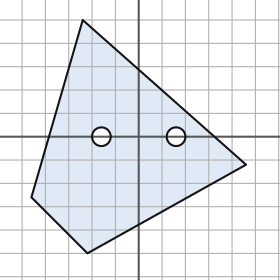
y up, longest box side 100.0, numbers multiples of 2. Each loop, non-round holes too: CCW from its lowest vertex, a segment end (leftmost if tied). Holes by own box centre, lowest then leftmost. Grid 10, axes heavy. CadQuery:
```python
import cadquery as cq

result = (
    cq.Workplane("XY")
    .moveTo(-22.0, -50.0)
    .lineTo(46.0, -12.0)
    .lineTo(-24.0, 50.0)
    .lineTo(-46.0, -26.0)
    .close()
    .moveTo(-16.0, 0.0)
    .circle(4.0)
    .moveTo(16.0, 0.0)
    .circle(4.0)
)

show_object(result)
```